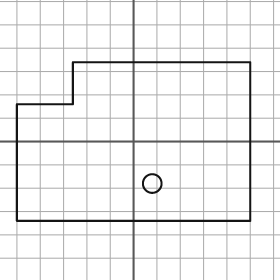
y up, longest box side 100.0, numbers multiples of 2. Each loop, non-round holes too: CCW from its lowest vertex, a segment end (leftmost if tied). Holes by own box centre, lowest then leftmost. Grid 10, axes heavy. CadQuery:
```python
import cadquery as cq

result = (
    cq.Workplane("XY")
    .moveTo(-50.0, -34.0)
    .lineTo(50.0, -34.0)
    .lineTo(50.0, 34.0)
    .lineTo(-26.0, 34.0)
    .lineTo(-26.0, 16.0)
    .lineTo(-50.0, 16.0)
    .close()
    .moveTo(8.0, -18.0)
    .circle(4.0)
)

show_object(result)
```